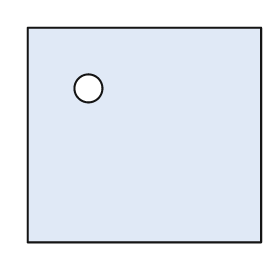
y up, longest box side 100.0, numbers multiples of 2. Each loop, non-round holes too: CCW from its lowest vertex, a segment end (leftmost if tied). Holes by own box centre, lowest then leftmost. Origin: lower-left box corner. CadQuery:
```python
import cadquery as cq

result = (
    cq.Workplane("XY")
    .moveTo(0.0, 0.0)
    .lineTo(100.0, 0.0)
    .lineTo(100.0, 92.0)
    .lineTo(0.0, 92.0)
    .close()
    .moveTo(26.0, 66.0)
    .circle(6.0)
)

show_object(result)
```